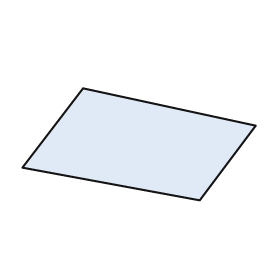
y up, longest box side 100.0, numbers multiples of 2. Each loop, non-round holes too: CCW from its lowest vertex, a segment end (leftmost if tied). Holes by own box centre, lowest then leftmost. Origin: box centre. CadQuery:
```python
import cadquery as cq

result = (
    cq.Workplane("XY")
    .moveTo(26.0, -24.0)
    .lineTo(50.0, 8.0)
    .lineTo(-24.0, 24.0)
    .lineTo(-50.0, -10.0)
    .close()
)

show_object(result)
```